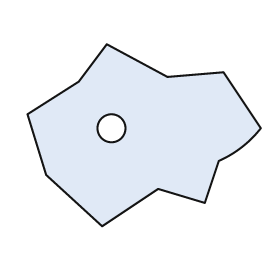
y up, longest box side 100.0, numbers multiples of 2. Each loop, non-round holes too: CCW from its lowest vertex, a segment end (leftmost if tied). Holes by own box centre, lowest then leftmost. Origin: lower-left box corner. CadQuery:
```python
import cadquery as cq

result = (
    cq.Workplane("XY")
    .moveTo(32.0, 0.0)
    .lineTo(56.0, 16.0)
    .lineTo(76.0, 10.0)
    .lineTo(82.0, 28.0)
    .threePointArc((92.0, 34.0), (100.0, 42.0))
    .lineTo(84.0, 66.0)
    .lineTo(60.0, 64.0)
    .lineTo(34.0, 78.0)
    .lineTo(22.0, 62.0)
    .lineTo(0.0, 48.0)
    .lineTo(8.0, 22.0)
    .close()
    .moveTo(36.0, 42.0)
    .circle(6.0)
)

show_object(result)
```